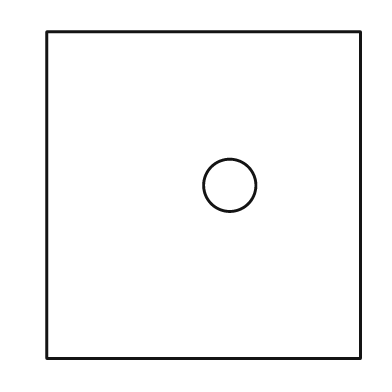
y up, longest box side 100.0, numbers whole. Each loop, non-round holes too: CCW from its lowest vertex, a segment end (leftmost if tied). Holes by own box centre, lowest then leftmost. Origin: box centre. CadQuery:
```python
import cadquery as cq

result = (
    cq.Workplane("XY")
    .moveTo(-48.0, -50.0)
    .lineTo(48.0, -50.0)
    .lineTo(48.0, 50.0)
    .lineTo(-48.0, 50.0)
    .close()
    .moveTo(8.0, 3.0)
    .circle(8.0)
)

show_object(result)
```